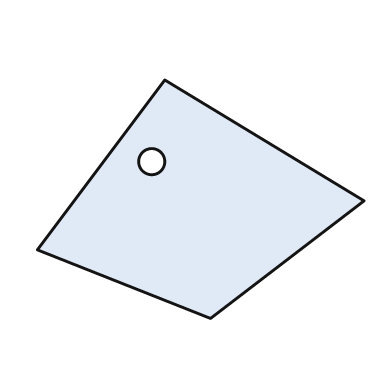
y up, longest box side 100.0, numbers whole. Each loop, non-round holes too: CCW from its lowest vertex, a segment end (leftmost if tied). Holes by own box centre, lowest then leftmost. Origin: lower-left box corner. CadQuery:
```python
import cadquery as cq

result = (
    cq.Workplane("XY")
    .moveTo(53.0, 0.0)
    .lineTo(100.0, 36.0)
    .lineTo(39.0, 73.0)
    .lineTo(0.0, 21.0)
    .close()
    .moveTo(35.0, 48.0)
    .circle(4.0)
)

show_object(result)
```